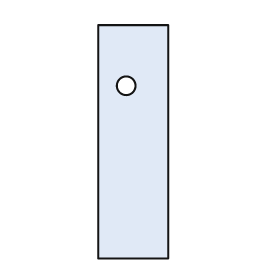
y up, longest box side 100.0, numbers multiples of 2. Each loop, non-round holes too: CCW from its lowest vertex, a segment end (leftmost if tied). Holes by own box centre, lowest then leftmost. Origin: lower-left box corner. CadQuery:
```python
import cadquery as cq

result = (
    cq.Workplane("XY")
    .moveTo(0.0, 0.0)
    .lineTo(30.0, 0.0)
    .lineTo(30.0, 100.0)
    .lineTo(0.0, 100.0)
    .close()
    .moveTo(12.0, 74.0)
    .circle(4.0)
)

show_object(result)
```